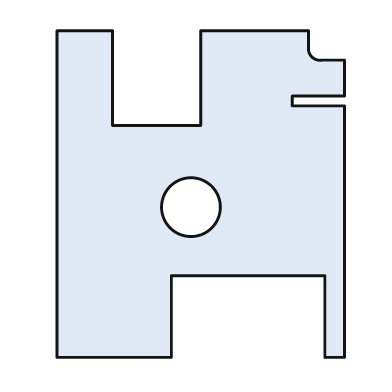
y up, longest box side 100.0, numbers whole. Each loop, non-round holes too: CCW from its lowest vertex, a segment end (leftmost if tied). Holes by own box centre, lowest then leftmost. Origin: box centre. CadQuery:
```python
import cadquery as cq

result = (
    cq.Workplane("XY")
    .moveTo(-44.0, -50.0)
    .lineTo(-9.0, -50.0)
    .lineTo(-9.0, -25.0)
    .lineTo(38.0, -25.0)
    .lineTo(38.0, -50.0)
    .lineTo(44.0, -50.0)
    .lineTo(44.0, 27.0)
    .lineTo(28.0, 27.0)
    .lineTo(28.0, 30.0)
    .lineTo(44.0, 30.0)
    .lineTo(44.0, 41.0)
    .lineTo(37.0, 41.0)
    .threePointArc((34.0, 42.0), (33.0, 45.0))
    .lineTo(33.0, 50.0)
    .lineTo(0.0, 50.0)
    .lineTo(0.0, 21.0)
    .lineTo(-27.0, 21.0)
    .lineTo(-27.0, 50.0)
    .lineTo(-44.0, 50.0)
    .close()
    .moveTo(-3.0, -4.0)
    .circle(9.0)
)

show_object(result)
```